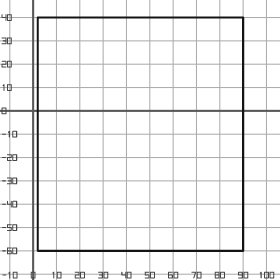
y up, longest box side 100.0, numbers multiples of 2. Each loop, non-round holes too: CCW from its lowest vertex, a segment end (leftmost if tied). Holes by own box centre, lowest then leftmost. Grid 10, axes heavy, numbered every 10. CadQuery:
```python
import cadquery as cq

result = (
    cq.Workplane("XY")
    .moveTo(2.0, -60.0)
    .lineTo(90.0, -60.0)
    .lineTo(90.0, 40.0)
    .lineTo(2.0, 40.0)
    .close()
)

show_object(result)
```